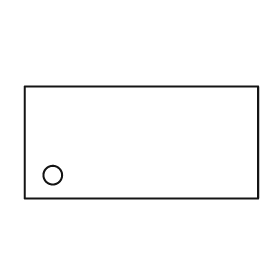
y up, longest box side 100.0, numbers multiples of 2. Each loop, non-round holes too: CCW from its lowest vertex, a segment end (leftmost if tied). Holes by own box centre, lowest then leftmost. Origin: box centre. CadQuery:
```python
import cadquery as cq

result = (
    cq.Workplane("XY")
    .moveTo(-50.0, -24.0)
    .lineTo(50.0, -24.0)
    .lineTo(50.0, 24.0)
    .lineTo(-50.0, 24.0)
    .close()
    .moveTo(-38.0, -14.0)
    .circle(4.0)
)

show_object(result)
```